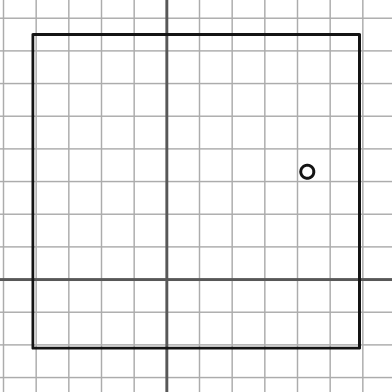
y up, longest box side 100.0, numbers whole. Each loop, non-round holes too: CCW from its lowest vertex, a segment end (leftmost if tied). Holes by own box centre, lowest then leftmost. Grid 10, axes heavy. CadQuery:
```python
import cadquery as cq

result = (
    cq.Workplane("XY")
    .moveTo(-41.0, -21.0)
    .lineTo(59.0, -21.0)
    .lineTo(59.0, 75.0)
    .lineTo(-41.0, 75.0)
    .close()
    .moveTo(43.0, 33.0)
    .circle(2.0)
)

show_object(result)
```